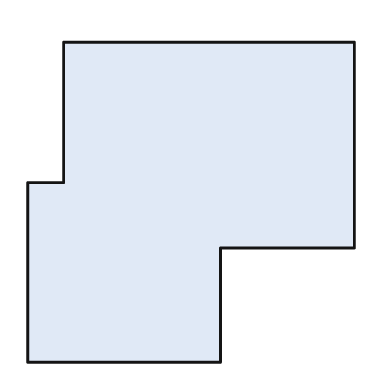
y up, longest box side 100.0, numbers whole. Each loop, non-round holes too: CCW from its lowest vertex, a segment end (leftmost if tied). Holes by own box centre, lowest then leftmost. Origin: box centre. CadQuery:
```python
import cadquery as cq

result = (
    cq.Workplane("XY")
    .moveTo(-50.0, -49.0)
    .lineTo(9.0, -49.0)
    .lineTo(9.0, -14.0)
    .lineTo(50.0, -14.0)
    .lineTo(50.0, 49.0)
    .lineTo(-39.0, 49.0)
    .lineTo(-39.0, 6.0)
    .lineTo(-50.0, 6.0)
    .close()
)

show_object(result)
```